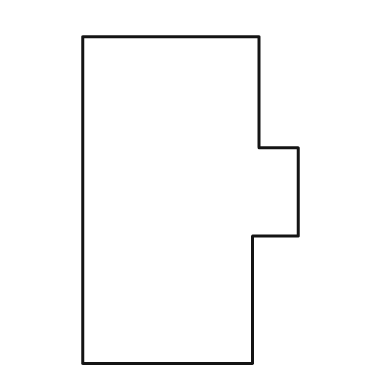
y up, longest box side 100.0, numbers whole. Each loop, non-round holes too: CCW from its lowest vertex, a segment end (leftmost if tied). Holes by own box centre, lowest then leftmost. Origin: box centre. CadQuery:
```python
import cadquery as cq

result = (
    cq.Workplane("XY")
    .moveTo(-33.0, -50.0)
    .lineTo(19.0, -50.0)
    .lineTo(19.0, -11.0)
    .lineTo(33.0, -11.0)
    .lineTo(33.0, 16.0)
    .lineTo(21.0, 16.0)
    .lineTo(21.0, 50.0)
    .lineTo(-33.0, 50.0)
    .close()
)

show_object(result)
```